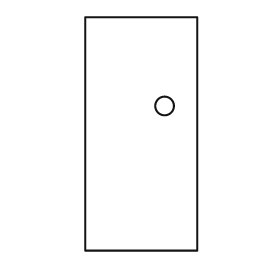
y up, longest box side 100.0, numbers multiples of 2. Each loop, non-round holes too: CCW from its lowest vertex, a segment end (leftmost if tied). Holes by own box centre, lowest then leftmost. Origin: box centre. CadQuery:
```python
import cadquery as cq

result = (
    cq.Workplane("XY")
    .moveTo(-24.0, -50.0)
    .lineTo(24.0, -50.0)
    .lineTo(24.0, 50.0)
    .lineTo(-24.0, 50.0)
    .close()
    .moveTo(10.0, 12.0)
    .circle(4.0)
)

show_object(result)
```